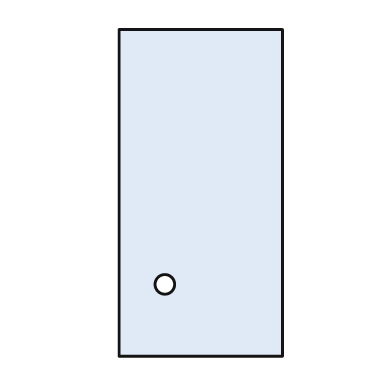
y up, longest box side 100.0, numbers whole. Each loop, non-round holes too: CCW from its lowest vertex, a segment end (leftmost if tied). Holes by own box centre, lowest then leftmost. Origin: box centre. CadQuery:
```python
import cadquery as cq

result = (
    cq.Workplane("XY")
    .moveTo(-25.0, -50.0)
    .lineTo(25.0, -50.0)
    .lineTo(25.0, 50.0)
    .lineTo(-25.0, 50.0)
    .close()
    .moveTo(-11.0, -28.0)
    .circle(3.0)
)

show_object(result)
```